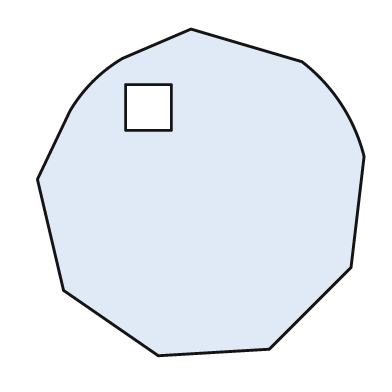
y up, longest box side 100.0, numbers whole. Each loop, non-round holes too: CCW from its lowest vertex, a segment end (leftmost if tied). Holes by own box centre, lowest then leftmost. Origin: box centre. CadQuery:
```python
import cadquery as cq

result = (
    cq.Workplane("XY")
    .moveTo(-13.0, -50.0)
    .lineTo(21.0, -48.0)
    .lineTo(46.0, -23.0)
    .lineTo(50.0, 11.0)
    .threePointArc((43.0, 27.0), (31.0, 40.0))
    .lineTo(-3.0, 50.0)
    .lineTo(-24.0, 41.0)
    .threePointArc((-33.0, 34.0), (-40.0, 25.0))
    .lineTo(-50.0, 4.0)
    .lineTo(-42.0, -30.0)
    .close()
    .moveTo(-23.0, 19.0)
    .lineTo(-9.0, 19.0)
    .lineTo(-9.0, 33.0)
    .lineTo(-23.0, 33.0)
    .close()
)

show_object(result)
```